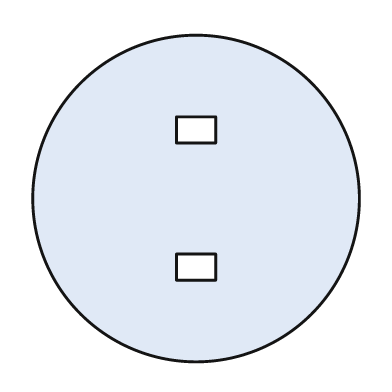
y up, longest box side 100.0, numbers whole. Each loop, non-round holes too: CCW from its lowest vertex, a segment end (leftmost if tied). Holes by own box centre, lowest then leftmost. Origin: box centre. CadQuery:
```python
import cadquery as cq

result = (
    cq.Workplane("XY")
    .moveTo(0.0, 0.0)
    .circle(50.0)
    .moveTo(-6.0, -25.0)
    .lineTo(6.0, -25.0)
    .lineTo(6.0, -17.0)
    .lineTo(-6.0, -17.0)
    .close()
    .moveTo(-6.0, 17.0)
    .lineTo(6.0, 17.0)
    .lineTo(6.0, 25.0)
    .lineTo(-6.0, 25.0)
    .close()
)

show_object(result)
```